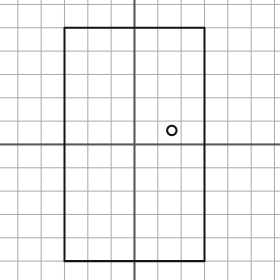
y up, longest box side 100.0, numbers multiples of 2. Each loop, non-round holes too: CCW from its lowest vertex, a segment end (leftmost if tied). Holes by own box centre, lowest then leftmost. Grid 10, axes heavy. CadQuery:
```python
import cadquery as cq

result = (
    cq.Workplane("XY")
    .moveTo(-30.0, -50.0)
    .lineTo(30.0, -50.0)
    .lineTo(30.0, 50.0)
    .lineTo(-30.0, 50.0)
    .close()
    .moveTo(16.0, 6.0)
    .circle(2.0)
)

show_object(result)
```